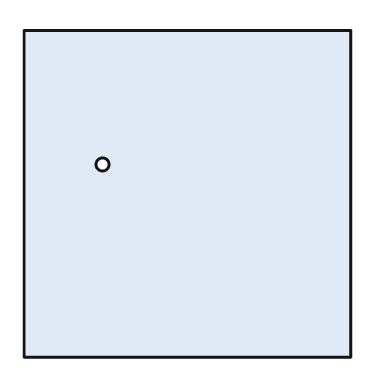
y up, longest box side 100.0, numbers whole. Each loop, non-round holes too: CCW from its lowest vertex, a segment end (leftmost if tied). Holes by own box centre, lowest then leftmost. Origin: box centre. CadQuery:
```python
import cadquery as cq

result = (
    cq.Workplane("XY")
    .moveTo(-50.0, -50.0)
    .lineTo(50.0, -50.0)
    .lineTo(50.0, 50.0)
    .lineTo(-50.0, 50.0)
    .close()
    .moveTo(-26.0, 9.0)
    .circle(2.0)
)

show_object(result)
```